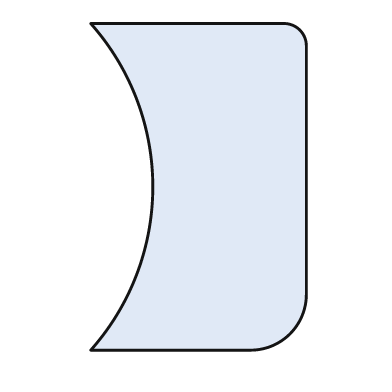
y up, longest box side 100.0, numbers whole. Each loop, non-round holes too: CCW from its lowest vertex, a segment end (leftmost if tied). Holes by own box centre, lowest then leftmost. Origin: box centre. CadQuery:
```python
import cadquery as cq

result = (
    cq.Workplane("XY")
    .moveTo(-33.0, -50.0)
    .lineTo(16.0, -50.0)
    .threePointArc((28.0, -45.0), (33.0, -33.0))
    .lineTo(33.0, 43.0)
    .threePointArc((31.0, 48.0), (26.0, 50.0))
    .lineTo(-33.0, 50.0)
    .threePointArc((-14.0, 0.0), (-33.0, -50.0))
    .close()
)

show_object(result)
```